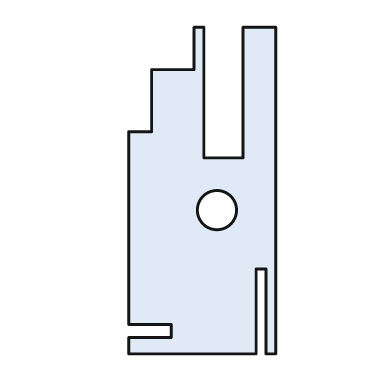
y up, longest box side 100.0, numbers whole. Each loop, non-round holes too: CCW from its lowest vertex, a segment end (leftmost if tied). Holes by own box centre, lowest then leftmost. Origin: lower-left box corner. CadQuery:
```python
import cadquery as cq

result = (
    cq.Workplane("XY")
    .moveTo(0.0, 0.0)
    .lineTo(39.0, 0.0)
    .lineTo(39.0, 26.0)
    .lineTo(42.0, 26.0)
    .lineTo(42.0, 0.0)
    .lineTo(45.0, 0.0)
    .lineTo(45.0, 100.0)
    .lineTo(35.0, 100.0)
    .lineTo(35.0, 60.0)
    .lineTo(23.0, 60.0)
    .lineTo(23.0, 100.0)
    .lineTo(20.0, 100.0)
    .lineTo(20.0, 87.0)
    .lineTo(7.0, 87.0)
    .lineTo(7.0, 68.0)
    .lineTo(0.0, 68.0)
    .lineTo(0.0, 9.0)
    .lineTo(13.0, 9.0)
    .lineTo(13.0, 5.0)
    .lineTo(0.0, 5.0)
    .close()
    .moveTo(27.0, 44.0)
    .circle(6.0)
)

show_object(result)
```